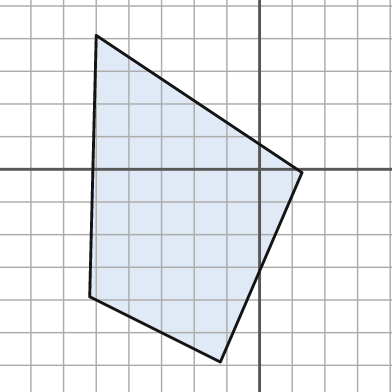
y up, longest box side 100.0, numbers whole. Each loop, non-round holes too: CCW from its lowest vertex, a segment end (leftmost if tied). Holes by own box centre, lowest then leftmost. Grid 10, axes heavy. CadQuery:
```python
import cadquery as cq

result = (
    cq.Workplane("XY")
    .moveTo(-12.0, -59.0)
    .lineTo(13.0, -1.0)
    .lineTo(-50.0, 41.0)
    .lineTo(-52.0, -39.0)
    .close()
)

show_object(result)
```